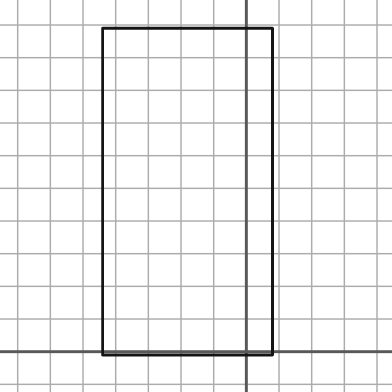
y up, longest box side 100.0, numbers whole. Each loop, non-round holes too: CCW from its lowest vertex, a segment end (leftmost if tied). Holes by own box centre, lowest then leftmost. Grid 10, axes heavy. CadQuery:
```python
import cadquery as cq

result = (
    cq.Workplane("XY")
    .moveTo(-44.0, -1.0)
    .lineTo(8.0, -1.0)
    .lineTo(8.0, 99.0)
    .lineTo(-44.0, 99.0)
    .close()
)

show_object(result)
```